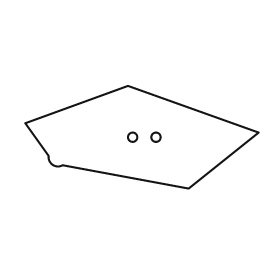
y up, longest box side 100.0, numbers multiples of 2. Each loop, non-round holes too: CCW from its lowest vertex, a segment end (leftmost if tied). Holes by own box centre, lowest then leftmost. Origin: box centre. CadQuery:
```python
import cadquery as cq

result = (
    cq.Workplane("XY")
    .moveTo(20.0, -22.0)
    .lineTo(50.0, 2.0)
    .lineTo(-6.0, 22.0)
    .lineTo(-50.0, 6.0)
    .lineTo(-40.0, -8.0)
    .threePointArc((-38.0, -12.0), (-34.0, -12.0))
    .close()
    .moveTo(-4.0, 0.0)
    .circle(2.0)
    .moveTo(6.0, 0.0)
    .circle(2.0)
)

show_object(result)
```